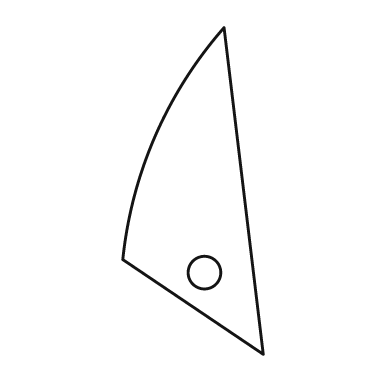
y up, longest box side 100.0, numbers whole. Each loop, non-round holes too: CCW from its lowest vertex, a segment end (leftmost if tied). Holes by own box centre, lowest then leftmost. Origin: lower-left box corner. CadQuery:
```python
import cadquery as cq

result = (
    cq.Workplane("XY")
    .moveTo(43.0, 0.0)
    .lineTo(31.0, 100.0)
    .threePointArc((10.0, 67.0), (0.0, 29.0))
    .close()
    .moveTo(25.0, 25.0)
    .circle(5.0)
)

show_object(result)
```